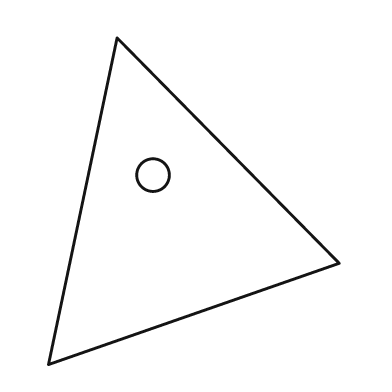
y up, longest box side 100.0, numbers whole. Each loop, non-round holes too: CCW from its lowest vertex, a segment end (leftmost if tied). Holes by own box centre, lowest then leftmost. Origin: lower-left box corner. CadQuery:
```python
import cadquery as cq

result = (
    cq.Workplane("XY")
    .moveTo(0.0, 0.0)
    .lineTo(89.0, 31.0)
    .lineTo(21.0, 100.0)
    .close()
    .moveTo(32.0, 58.0)
    .circle(5.0)
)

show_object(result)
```